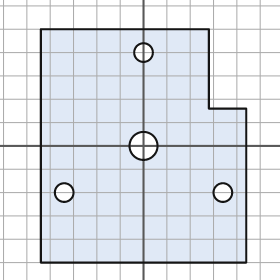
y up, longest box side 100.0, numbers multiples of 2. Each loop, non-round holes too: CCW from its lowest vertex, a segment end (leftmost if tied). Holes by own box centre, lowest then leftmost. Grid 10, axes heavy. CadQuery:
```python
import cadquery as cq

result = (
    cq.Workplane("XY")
    .moveTo(-44.0, -50.0)
    .lineTo(44.0, -50.0)
    .lineTo(44.0, 16.0)
    .lineTo(28.0, 16.0)
    .lineTo(28.0, 50.0)
    .lineTo(-44.0, 50.0)
    .close()
    .moveTo(-34.0, -20.0)
    .circle(4.0)
    .moveTo(34.0, -20.0)
    .circle(4.0)
    .moveTo(0.0, 0.0)
    .circle(6.0)
    .moveTo(0.0, 40.0)
    .circle(4.0)
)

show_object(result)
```